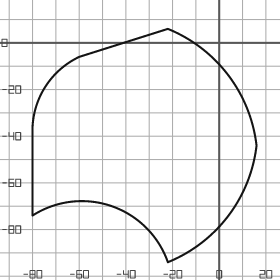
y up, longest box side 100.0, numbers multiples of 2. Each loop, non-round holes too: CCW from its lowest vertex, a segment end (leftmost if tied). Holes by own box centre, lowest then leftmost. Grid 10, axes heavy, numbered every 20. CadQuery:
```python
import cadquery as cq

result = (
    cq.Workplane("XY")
    .moveTo(-22.0, -94.0)
    .threePointArc((4.0, -74.0), (16.0, -44.0))
    .threePointArc((4.0, -14.0), (-22.0, 6.0))
    .lineTo(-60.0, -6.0)
    .threePointArc((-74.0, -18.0), (-80.0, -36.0))
    .lineTo(-80.0, -74.0)
    .threePointArc((-46.0, -70.0), (-22.0, -94.0))
    .close()
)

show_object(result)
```